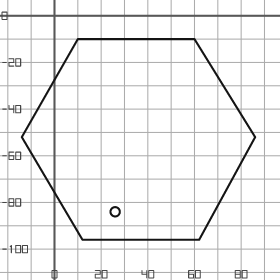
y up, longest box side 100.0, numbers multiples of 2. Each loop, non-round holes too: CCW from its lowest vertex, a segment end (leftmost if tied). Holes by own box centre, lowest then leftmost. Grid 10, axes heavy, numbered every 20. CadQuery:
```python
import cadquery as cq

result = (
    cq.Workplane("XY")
    .moveTo(12.0, -96.0)
    .lineTo(62.0, -96.0)
    .lineTo(86.0, -52.0)
    .lineTo(60.0, -10.0)
    .lineTo(10.0, -10.0)
    .lineTo(-14.0, -52.0)
    .close()
    .moveTo(26.0, -84.0)
    .circle(2.0)
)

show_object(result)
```